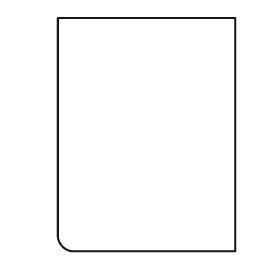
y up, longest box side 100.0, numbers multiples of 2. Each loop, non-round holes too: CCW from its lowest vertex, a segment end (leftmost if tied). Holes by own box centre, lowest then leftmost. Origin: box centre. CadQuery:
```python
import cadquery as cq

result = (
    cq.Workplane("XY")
    .moveTo(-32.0, -50.0)
    .lineTo(38.0, -50.0)
    .lineTo(38.0, 50.0)
    .lineTo(-38.0, 50.0)
    .lineTo(-38.0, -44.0)
    .threePointArc((-36.0, -48.0), (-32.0, -50.0))
    .close()
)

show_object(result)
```